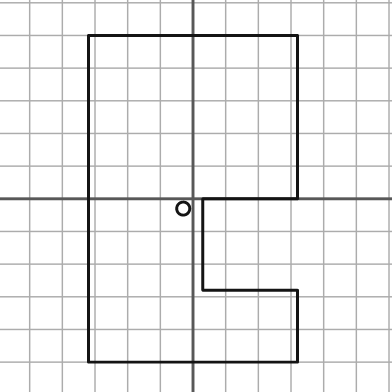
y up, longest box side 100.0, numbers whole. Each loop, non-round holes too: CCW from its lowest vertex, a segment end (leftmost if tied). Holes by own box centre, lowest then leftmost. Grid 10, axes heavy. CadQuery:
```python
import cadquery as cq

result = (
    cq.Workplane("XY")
    .moveTo(-32.0, -50.0)
    .lineTo(32.0, -50.0)
    .lineTo(32.0, -28.0)
    .lineTo(3.0, -28.0)
    .lineTo(3.0, 0.0)
    .lineTo(32.0, 0.0)
    .lineTo(32.0, 50.0)
    .lineTo(-32.0, 50.0)
    .close()
    .moveTo(-3.0, -3.0)
    .circle(2.0)
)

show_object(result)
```